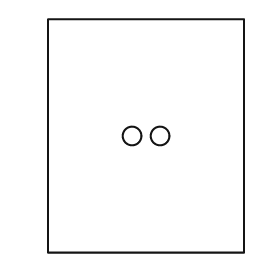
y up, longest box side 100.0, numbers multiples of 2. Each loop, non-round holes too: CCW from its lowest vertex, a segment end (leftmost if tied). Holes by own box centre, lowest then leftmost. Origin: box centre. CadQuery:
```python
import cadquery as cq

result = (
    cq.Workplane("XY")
    .moveTo(-42.0, -50.0)
    .lineTo(42.0, -50.0)
    .lineTo(42.0, 50.0)
    .lineTo(-42.0, 50.0)
    .close()
    .moveTo(-6.0, 0.0)
    .circle(4.0)
    .moveTo(6.0, 0.0)
    .circle(4.0)
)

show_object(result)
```